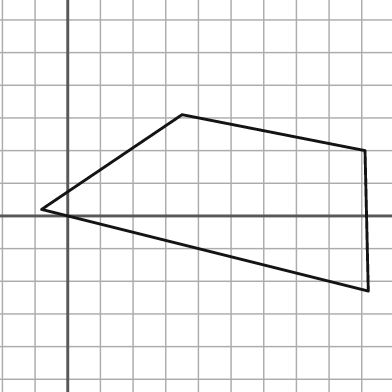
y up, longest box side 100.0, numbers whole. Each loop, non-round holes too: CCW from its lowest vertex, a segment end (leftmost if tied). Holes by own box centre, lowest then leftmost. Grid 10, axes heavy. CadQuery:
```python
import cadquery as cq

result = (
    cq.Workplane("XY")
    .moveTo(92.0, -23.0)
    .lineTo(91.0, 20.0)
    .lineTo(35.0, 31.0)
    .lineTo(-8.0, 2.0)
    .close()
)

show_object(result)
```